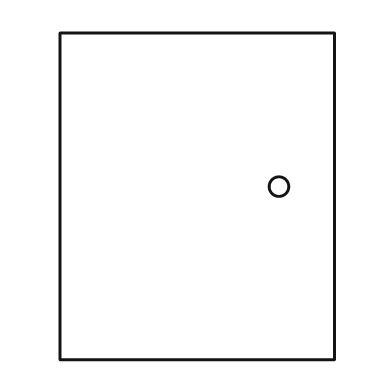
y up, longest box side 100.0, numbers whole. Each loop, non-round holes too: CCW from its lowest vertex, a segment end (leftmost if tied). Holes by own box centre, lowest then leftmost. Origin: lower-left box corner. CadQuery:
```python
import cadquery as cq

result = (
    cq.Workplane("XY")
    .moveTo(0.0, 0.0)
    .lineTo(84.0, 0.0)
    .lineTo(84.0, 100.0)
    .lineTo(0.0, 100.0)
    .close()
    .moveTo(67.0, 53.0)
    .circle(3.0)
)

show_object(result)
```